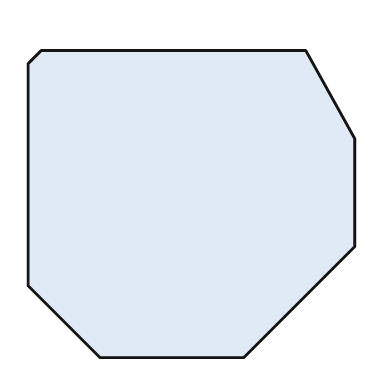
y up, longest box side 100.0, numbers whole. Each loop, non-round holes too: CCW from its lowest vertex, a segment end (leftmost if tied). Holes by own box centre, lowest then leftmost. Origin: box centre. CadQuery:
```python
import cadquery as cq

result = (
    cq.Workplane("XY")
    .moveTo(-28.0, -47.0)
    .lineTo(16.0, -47.0)
    .lineTo(50.0, -13.0)
    .lineTo(50.0, 20.0)
    .lineTo(35.0, 47.0)
    .lineTo(-46.0, 47.0)
    .lineTo(-50.0, 43.0)
    .lineTo(-50.0, -25.0)
    .close()
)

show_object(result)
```